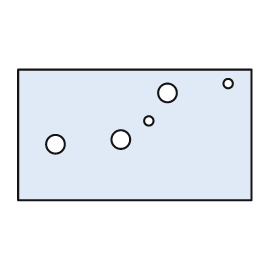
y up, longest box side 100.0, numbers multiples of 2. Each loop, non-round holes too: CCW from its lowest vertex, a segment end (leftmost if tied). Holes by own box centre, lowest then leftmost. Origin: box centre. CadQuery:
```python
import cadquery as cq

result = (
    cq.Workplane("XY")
    .moveTo(-50.0, -28.0)
    .lineTo(50.0, -28.0)
    .lineTo(50.0, 28.0)
    .lineTo(-50.0, 28.0)
    .close()
    .moveTo(-34.0, -4.0)
    .circle(4.0)
    .moveTo(-6.0, -2.0)
    .circle(4.0)
    .moveTo(6.0, 6.0)
    .circle(2.0)
    .moveTo(14.0, 18.0)
    .circle(4.0)
    .moveTo(40.0, 22.0)
    .circle(2.0)
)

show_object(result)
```